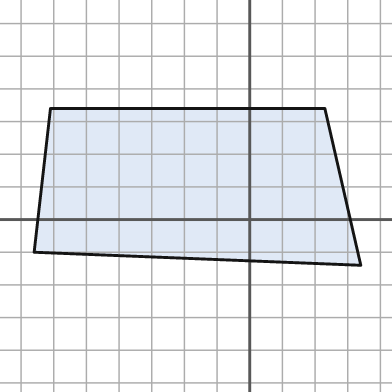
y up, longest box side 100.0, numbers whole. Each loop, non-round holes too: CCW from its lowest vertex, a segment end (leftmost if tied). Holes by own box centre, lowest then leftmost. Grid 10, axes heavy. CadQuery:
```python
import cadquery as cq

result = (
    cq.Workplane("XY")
    .moveTo(34.0, -14.0)
    .lineTo(23.0, 34.0)
    .lineTo(-61.0, 34.0)
    .lineTo(-66.0, -10.0)
    .close()
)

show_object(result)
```